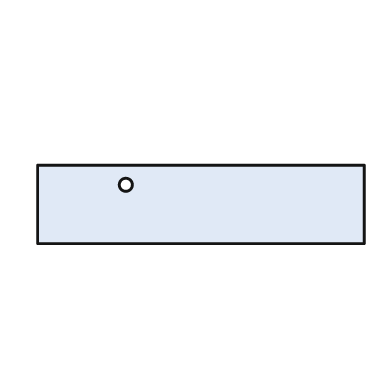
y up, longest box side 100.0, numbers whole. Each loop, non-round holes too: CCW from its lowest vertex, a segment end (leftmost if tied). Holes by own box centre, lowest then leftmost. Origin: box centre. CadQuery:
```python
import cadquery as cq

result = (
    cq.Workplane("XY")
    .moveTo(-50.0, -12.0)
    .lineTo(50.0, -12.0)
    .lineTo(50.0, 12.0)
    .lineTo(-50.0, 12.0)
    .close()
    .moveTo(-23.0, 6.0)
    .circle(2.0)
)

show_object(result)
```